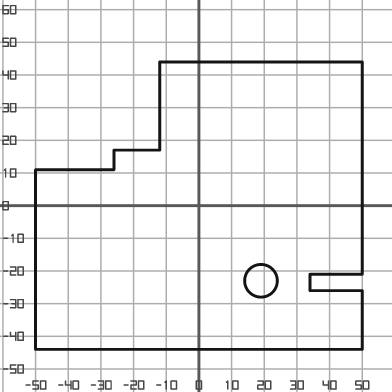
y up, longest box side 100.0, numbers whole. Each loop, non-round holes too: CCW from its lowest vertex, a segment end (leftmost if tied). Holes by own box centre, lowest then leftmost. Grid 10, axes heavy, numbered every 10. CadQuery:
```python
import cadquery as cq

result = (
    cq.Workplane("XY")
    .moveTo(-50.0, -44.0)
    .lineTo(50.0, -44.0)
    .lineTo(50.0, -26.0)
    .lineTo(34.0, -26.0)
    .lineTo(34.0, -21.0)
    .lineTo(50.0, -21.0)
    .lineTo(50.0, 44.0)
    .lineTo(-12.0, 44.0)
    .lineTo(-12.0, 17.0)
    .lineTo(-26.0, 17.0)
    .lineTo(-26.0, 11.0)
    .lineTo(-50.0, 11.0)
    .close()
    .moveTo(19.0, -23.0)
    .circle(5.0)
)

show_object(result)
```